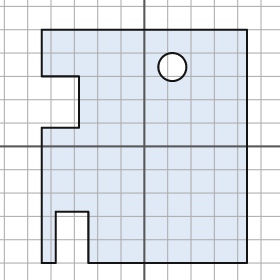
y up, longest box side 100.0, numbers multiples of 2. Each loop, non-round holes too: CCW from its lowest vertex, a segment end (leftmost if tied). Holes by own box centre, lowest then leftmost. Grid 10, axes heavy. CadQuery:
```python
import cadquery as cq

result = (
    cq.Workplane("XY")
    .moveTo(-44.0, -50.0)
    .lineTo(-38.0, -50.0)
    .lineTo(-38.0, -28.0)
    .lineTo(-24.0, -28.0)
    .lineTo(-24.0, -50.0)
    .lineTo(44.0, -50.0)
    .lineTo(44.0, 50.0)
    .lineTo(-44.0, 50.0)
    .lineTo(-44.0, 30.0)
    .lineTo(-28.0, 30.0)
    .lineTo(-28.0, 8.0)
    .lineTo(-44.0, 8.0)
    .close()
    .moveTo(12.0, 34.0)
    .circle(6.0)
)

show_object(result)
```